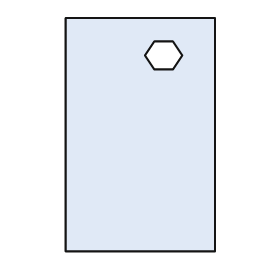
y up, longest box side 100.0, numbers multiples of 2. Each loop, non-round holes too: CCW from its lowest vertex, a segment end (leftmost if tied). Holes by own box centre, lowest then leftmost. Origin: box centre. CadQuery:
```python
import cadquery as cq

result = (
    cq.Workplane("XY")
    .moveTo(-32.0, -50.0)
    .lineTo(32.0, -50.0)
    .lineTo(32.0, 50.0)
    .lineTo(-32.0, 50.0)
    .close()
    .moveTo(6.0, 28.0)
    .lineTo(14.0, 28.0)
    .lineTo(18.0, 34.0)
    .lineTo(14.0, 40.0)
    .lineTo(6.0, 40.0)
    .lineTo(2.0, 34.0)
    .close()
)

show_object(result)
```